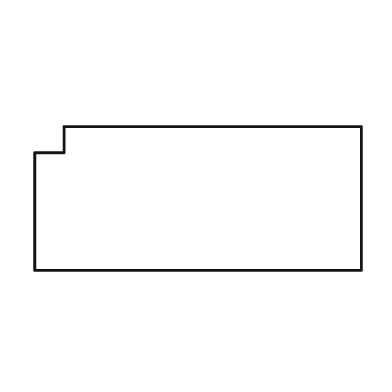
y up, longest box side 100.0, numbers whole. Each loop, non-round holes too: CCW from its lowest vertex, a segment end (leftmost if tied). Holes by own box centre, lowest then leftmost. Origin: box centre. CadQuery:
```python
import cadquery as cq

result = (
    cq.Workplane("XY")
    .moveTo(-50.0, -22.0)
    .lineTo(50.0, -22.0)
    .lineTo(50.0, 22.0)
    .lineTo(-41.0, 22.0)
    .lineTo(-41.0, 14.0)
    .lineTo(-50.0, 14.0)
    .close()
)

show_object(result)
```